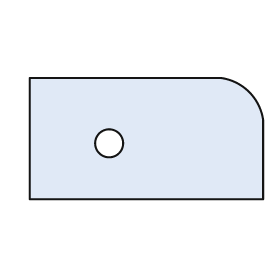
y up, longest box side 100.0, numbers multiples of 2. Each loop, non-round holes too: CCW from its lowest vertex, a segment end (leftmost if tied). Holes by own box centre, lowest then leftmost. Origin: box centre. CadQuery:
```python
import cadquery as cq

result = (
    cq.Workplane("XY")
    .moveTo(-50.0, -26.0)
    .lineTo(50.0, -26.0)
    .lineTo(50.0, 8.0)
    .threePointArc((44.0, 20.0), (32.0, 26.0))
    .lineTo(-50.0, 26.0)
    .close()
    .moveTo(-16.0, -2.0)
    .circle(6.0)
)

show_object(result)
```